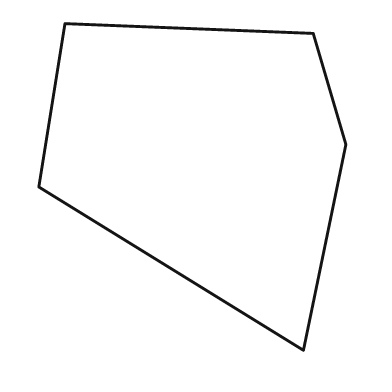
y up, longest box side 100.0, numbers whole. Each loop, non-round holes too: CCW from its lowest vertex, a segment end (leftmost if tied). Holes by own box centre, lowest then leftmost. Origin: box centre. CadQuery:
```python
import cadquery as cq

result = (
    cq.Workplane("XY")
    .moveTo(34.0, -50.0)
    .lineTo(47.0, 13.0)
    .lineTo(37.0, 47.0)
    .lineTo(-39.0, 50.0)
    .lineTo(-47.0, 0.0)
    .close()
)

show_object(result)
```